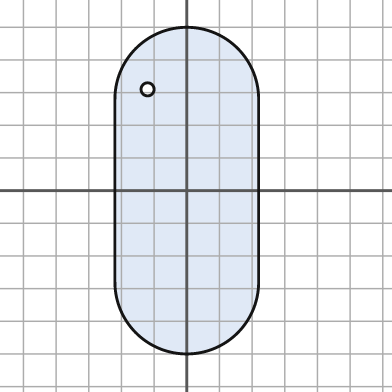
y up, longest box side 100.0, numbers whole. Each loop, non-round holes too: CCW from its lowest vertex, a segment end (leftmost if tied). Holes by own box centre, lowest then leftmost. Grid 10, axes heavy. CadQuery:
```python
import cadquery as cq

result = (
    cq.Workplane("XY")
    .moveTo(-22.0, -28.0)
    .threePointArc((0.0, -50.0), (22.0, -28.0))
    .lineTo(22.0, 28.0)
    .threePointArc((0.0, 50.0), (-22.0, 28.0))
    .close()
    .moveTo(-12.0, 31.0)
    .circle(2.0)
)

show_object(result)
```